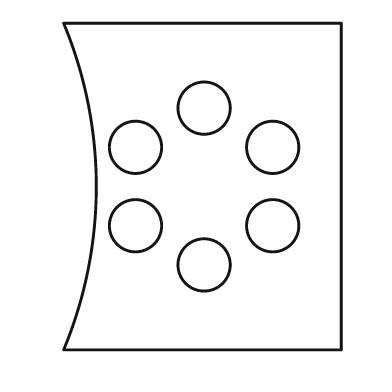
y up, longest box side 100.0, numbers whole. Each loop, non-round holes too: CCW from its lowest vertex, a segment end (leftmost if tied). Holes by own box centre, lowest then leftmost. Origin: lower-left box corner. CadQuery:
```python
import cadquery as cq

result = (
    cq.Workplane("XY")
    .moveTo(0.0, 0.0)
    .lineTo(85.0, 0.0)
    .lineTo(85.0, 100.0)
    .lineTo(0.0, 100.0)
    .threePointArc((10.0, 50.0), (0.0, 0.0))
    .close()
    .moveTo(43.0, 26.0)
    .circle(8.0)
    .moveTo(22.0, 38.0)
    .circle(8.0)
    .moveTo(64.0, 38.0)
    .circle(8.0)
    .moveTo(22.0, 62.0)
    .circle(8.0)
    .moveTo(64.0, 62.0)
    .circle(8.0)
    .moveTo(43.0, 74.0)
    .circle(8.0)
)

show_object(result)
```